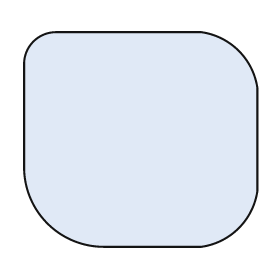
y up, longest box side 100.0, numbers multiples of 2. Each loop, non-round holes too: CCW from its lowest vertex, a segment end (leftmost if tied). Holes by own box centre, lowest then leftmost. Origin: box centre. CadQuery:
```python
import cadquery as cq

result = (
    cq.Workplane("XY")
    .moveTo(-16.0, -46.0)
    .lineTo(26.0, -46.0)
    .threePointArc((42.0, -38.0), (50.0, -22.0))
    .lineTo(50.0, 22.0)
    .threePointArc((42.0, 38.0), (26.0, 46.0))
    .lineTo(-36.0, 46.0)
    .threePointArc((-46.0, 42.0), (-50.0, 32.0))
    .lineTo(-50.0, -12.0)
    .threePointArc((-40.0, -36.0), (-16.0, -46.0))
    .close()
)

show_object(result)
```